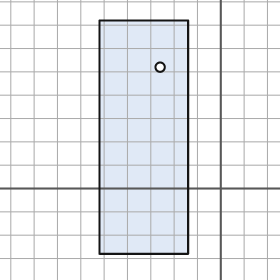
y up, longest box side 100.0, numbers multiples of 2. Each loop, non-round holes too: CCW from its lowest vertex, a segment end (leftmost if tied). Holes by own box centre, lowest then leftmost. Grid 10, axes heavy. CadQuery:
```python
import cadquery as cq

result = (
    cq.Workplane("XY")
    .moveTo(-52.0, -28.0)
    .lineTo(-14.0, -28.0)
    .lineTo(-14.0, 72.0)
    .lineTo(-52.0, 72.0)
    .close()
    .moveTo(-26.0, 52.0)
    .circle(2.0)
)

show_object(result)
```